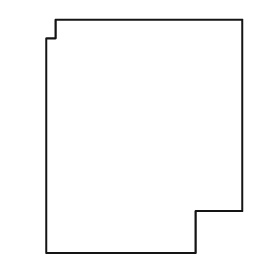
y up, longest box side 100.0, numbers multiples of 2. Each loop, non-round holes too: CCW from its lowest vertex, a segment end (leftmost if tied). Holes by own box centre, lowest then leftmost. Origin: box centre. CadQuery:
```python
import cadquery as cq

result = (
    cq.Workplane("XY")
    .moveTo(-42.0, -50.0)
    .lineTo(22.0, -50.0)
    .lineTo(22.0, -32.0)
    .lineTo(42.0, -32.0)
    .lineTo(42.0, 50.0)
    .lineTo(-38.0, 50.0)
    .lineTo(-38.0, 42.0)
    .lineTo(-42.0, 42.0)
    .close()
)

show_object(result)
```